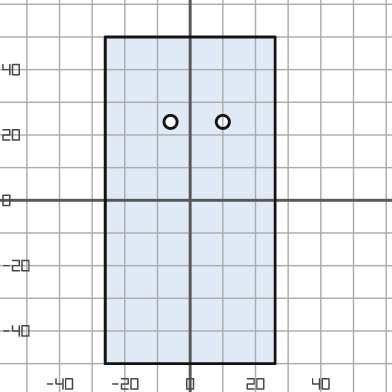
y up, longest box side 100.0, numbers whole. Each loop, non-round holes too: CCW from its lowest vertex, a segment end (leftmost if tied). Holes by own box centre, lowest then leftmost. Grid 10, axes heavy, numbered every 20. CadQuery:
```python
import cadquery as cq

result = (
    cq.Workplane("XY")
    .moveTo(-26.0, -50.0)
    .lineTo(26.0, -50.0)
    .lineTo(26.0, 50.0)
    .lineTo(-26.0, 50.0)
    .close()
    .moveTo(-6.0, 24.0)
    .circle(2.0)
    .moveTo(10.0, 24.0)
    .circle(2.0)
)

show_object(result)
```